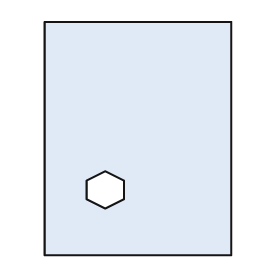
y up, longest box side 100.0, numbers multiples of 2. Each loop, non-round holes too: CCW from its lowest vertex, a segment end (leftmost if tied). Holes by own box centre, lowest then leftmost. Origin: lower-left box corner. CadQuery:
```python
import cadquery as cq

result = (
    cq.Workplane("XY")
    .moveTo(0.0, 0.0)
    .lineTo(80.0, 0.0)
    .lineTo(80.0, 100.0)
    .lineTo(0.0, 100.0)
    .close()
    .moveTo(26.0, 20.0)
    .lineTo(34.0, 24.0)
    .lineTo(34.0, 32.0)
    .lineTo(26.0, 36.0)
    .lineTo(18.0, 32.0)
    .lineTo(18.0, 24.0)
    .close()
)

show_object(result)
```